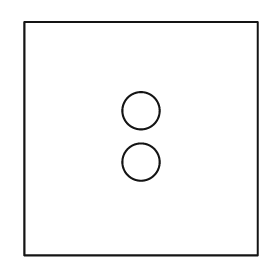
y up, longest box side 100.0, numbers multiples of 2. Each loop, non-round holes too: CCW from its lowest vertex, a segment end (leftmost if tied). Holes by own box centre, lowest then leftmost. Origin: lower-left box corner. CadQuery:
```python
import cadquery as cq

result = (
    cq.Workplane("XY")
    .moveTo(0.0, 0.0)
    .lineTo(100.0, 0.0)
    .lineTo(100.0, 100.0)
    .lineTo(0.0, 100.0)
    .close()
    .moveTo(50.0, 40.0)
    .circle(8.0)
    .moveTo(50.0, 62.0)
    .circle(8.0)
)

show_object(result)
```